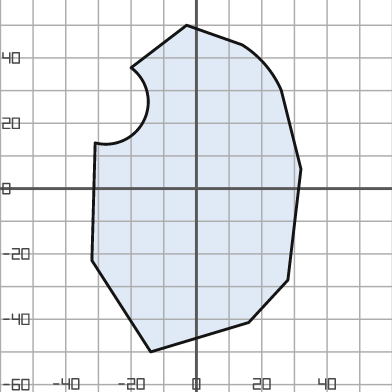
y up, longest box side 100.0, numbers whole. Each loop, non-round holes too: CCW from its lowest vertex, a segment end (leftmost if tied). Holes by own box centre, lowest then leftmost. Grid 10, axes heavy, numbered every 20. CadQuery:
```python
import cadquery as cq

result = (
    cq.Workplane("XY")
    .moveTo(-14.0, -50.0)
    .lineTo(16.0, -41.0)
    .lineTo(28.0, -28.0)
    .lineTo(32.0, 6.0)
    .lineTo(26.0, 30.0)
    .threePointArc((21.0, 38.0), (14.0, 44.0))
    .lineTo(-3.0, 50.0)
    .lineTo(-20.0, 37.0)
    .threePointArc((-16.0, 21.0), (-31.0, 14.0))
    .lineTo(-32.0, -22.0)
    .close()
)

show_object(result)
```